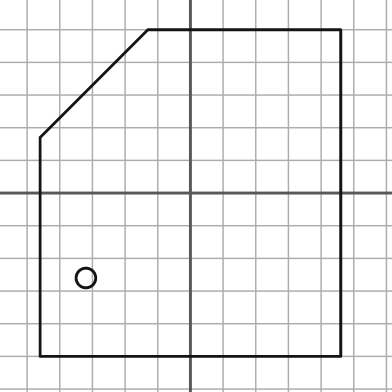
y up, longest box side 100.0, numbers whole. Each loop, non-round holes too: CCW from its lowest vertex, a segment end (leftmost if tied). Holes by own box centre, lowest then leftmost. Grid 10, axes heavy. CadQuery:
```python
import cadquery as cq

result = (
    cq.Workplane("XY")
    .moveTo(-46.0, -50.0)
    .lineTo(46.0, -50.0)
    .lineTo(46.0, 50.0)
    .lineTo(-13.0, 50.0)
    .lineTo(-46.0, 17.0)
    .close()
    .moveTo(-32.0, -26.0)
    .circle(3.0)
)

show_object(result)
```